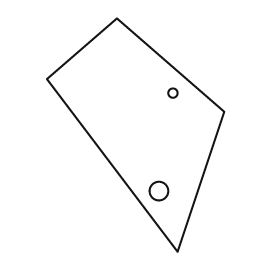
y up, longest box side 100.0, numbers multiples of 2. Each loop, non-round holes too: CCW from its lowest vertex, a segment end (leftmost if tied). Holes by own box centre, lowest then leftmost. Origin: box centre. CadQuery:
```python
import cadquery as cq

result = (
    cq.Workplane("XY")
    .moveTo(18.0, -50.0)
    .lineTo(38.0, 10.0)
    .lineTo(-8.0, 50.0)
    .lineTo(-38.0, 24.0)
    .close()
    .moveTo(10.0, -24.0)
    .circle(4.0)
    .moveTo(16.0, 18.0)
    .circle(2.0)
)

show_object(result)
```